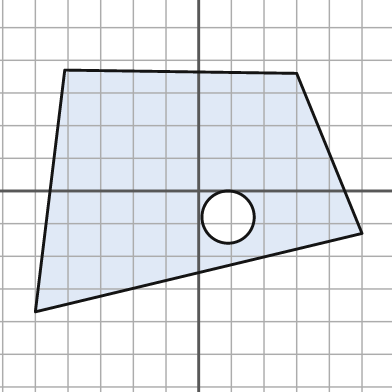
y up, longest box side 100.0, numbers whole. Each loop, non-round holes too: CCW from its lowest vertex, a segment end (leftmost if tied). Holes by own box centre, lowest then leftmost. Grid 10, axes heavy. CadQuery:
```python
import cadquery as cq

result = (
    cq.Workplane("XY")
    .moveTo(-50.0, -37.0)
    .lineTo(50.0, -13.0)
    .lineTo(30.0, 36.0)
    .lineTo(-41.0, 37.0)
    .close()
    .moveTo(9.0, -8.0)
    .circle(8.0)
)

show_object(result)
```